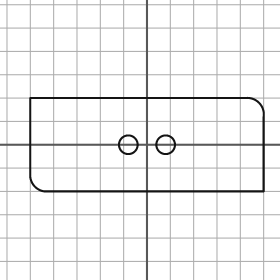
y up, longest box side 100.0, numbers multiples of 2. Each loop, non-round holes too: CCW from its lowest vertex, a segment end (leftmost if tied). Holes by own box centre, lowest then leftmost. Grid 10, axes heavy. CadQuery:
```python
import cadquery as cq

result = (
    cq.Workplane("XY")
    .moveTo(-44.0, -20.0)
    .lineTo(50.0, -20.0)
    .lineTo(50.0, 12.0)
    .threePointArc((48.0, 18.0), (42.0, 20.0))
    .lineTo(-50.0, 20.0)
    .lineTo(-50.0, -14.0)
    .threePointArc((-48.0, -18.0), (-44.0, -20.0))
    .close()
    .moveTo(-8.0, 0.0)
    .circle(4.0)
    .moveTo(8.0, 0.0)
    .circle(4.0)
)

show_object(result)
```